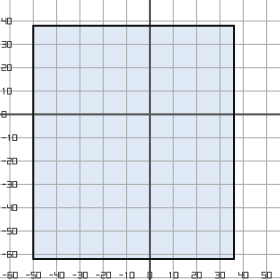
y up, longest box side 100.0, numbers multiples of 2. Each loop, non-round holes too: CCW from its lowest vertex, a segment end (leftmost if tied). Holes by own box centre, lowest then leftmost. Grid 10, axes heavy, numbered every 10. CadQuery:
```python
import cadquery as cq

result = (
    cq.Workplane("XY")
    .moveTo(-50.0, -62.0)
    .lineTo(36.0, -62.0)
    .lineTo(36.0, 38.0)
    .lineTo(-50.0, 38.0)
    .close()
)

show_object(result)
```